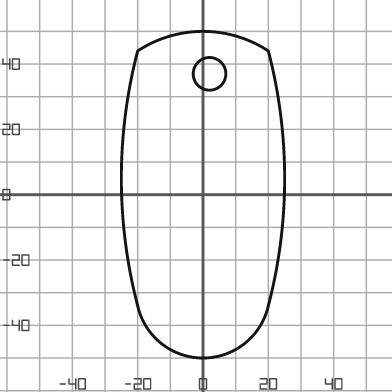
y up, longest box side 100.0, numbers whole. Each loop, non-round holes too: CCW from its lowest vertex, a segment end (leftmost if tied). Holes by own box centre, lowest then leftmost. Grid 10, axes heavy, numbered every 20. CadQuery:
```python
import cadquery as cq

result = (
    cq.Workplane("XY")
    .moveTo(-20.0, -34.0)
    .threePointArc((0.0, -50.0), (20.0, -34.0))
    .threePointArc((25.0, 5.0), (20.0, 44.0))
    .threePointArc((0.0, 50.0), (-20.0, 44.0))
    .threePointArc((-25.0, 5.0), (-20.0, -34.0))
    .close()
    .moveTo(2.0, 37.0)
    .circle(5.0)
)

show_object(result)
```